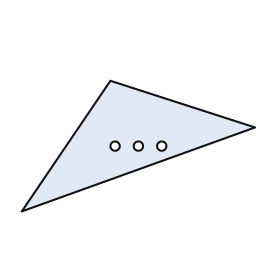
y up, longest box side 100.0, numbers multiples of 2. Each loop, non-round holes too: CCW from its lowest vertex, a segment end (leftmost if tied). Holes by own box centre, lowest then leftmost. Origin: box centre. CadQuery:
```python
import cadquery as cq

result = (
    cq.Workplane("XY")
    .moveTo(-50.0, -28.0)
    .lineTo(50.0, 8.0)
    .lineTo(-12.0, 28.0)
    .close()
    .moveTo(-10.0, 0.0)
    .circle(2.0)
    .moveTo(0.0, 0.0)
    .circle(2.0)
    .moveTo(10.0, 0.0)
    .circle(2.0)
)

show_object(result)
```